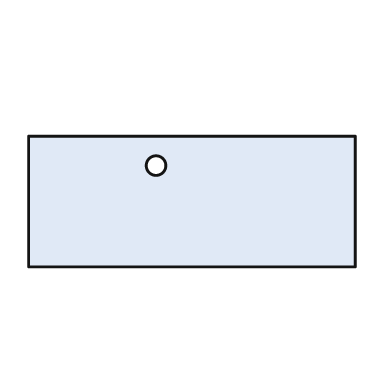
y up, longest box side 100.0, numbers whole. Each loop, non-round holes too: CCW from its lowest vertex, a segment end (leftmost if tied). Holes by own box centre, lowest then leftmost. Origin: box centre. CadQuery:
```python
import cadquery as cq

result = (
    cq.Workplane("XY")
    .moveTo(-50.0, -20.0)
    .lineTo(50.0, -20.0)
    .lineTo(50.0, 20.0)
    .lineTo(-50.0, 20.0)
    .close()
    .moveTo(-11.0, 11.0)
    .circle(3.0)
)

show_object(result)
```